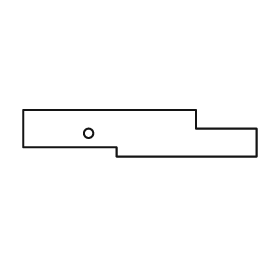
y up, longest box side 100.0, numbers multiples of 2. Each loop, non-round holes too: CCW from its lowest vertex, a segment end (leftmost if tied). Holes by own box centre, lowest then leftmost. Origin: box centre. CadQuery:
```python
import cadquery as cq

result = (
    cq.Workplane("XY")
    .moveTo(-10.0, -10.0)
    .lineTo(50.0, -10.0)
    .lineTo(50.0, 2.0)
    .lineTo(24.0, 2.0)
    .lineTo(24.0, 10.0)
    .lineTo(-50.0, 10.0)
    .lineTo(-50.0, -6.0)
    .lineTo(-10.0, -6.0)
    .close()
    .moveTo(-22.0, 0.0)
    .circle(2.0)
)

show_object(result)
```